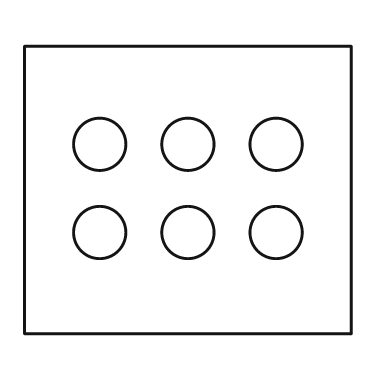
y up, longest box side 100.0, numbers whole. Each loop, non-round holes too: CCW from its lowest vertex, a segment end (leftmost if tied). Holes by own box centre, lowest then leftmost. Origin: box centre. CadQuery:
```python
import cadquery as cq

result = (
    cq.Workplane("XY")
    .moveTo(-50.0, -44.0)
    .lineTo(50.0, -44.0)
    .lineTo(50.0, 44.0)
    .lineTo(-50.0, 44.0)
    .close()
    .moveTo(-27.0, -13.0)
    .circle(8.0)
    .moveTo(0.0, -13.0)
    .circle(8.0)
    .moveTo(27.0, -13.0)
    .circle(8.0)
    .moveTo(-27.0, 14.0)
    .circle(8.0)
    .moveTo(0.0, 14.0)
    .circle(8.0)
    .moveTo(27.0, 14.0)
    .circle(8.0)
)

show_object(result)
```